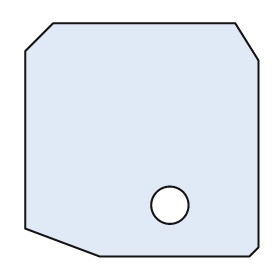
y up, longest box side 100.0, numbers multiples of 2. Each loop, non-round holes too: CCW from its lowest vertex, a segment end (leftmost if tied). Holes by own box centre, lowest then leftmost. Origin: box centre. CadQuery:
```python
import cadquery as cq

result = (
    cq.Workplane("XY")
    .moveTo(-18.0, -50.0)
    .lineTo(46.0, -50.0)
    .lineTo(50.0, -46.0)
    .lineTo(50.0, 34.0)
    .lineTo(40.0, 50.0)
    .lineTo(-38.0, 50.0)
    .lineTo(-50.0, 38.0)
    .lineTo(-50.0, -38.0)
    .close()
    .moveTo(12.0, -28.0)
    .circle(8.0)
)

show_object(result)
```